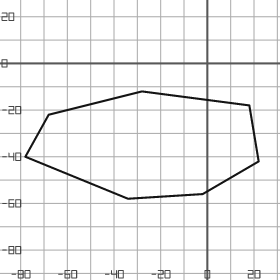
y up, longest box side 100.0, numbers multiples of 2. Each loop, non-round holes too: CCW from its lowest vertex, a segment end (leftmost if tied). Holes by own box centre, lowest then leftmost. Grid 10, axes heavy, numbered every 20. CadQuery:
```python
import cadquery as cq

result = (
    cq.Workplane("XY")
    .moveTo(-34.0, -58.0)
    .lineTo(-2.0, -56.0)
    .lineTo(22.0, -42.0)
    .lineTo(18.0, -18.0)
    .lineTo(-28.0, -12.0)
    .lineTo(-68.0, -22.0)
    .lineTo(-78.0, -40.0)
    .close()
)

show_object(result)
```